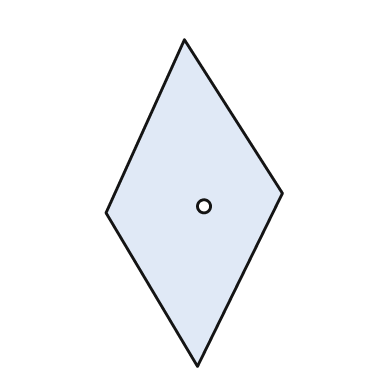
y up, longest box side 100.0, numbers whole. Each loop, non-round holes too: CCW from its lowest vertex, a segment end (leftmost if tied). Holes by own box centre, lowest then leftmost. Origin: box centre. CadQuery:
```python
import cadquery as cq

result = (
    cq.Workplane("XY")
    .moveTo(1.0, -50.0)
    .lineTo(27.0, 3.0)
    .lineTo(-3.0, 50.0)
    .lineTo(-27.0, -3.0)
    .close()
    .moveTo(3.0, -1.0)
    .circle(2.0)
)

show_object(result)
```